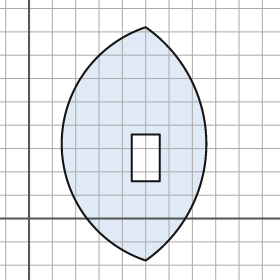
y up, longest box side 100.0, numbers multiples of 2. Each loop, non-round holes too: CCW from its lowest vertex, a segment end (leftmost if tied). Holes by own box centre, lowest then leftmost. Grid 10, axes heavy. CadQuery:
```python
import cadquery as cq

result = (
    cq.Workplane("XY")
    .moveTo(50.0, -18.0)
    .threePointArc((76.0, 32.0), (50.0, 82.0))
    .threePointArc((14.0, 32.0), (50.0, -18.0))
    .close()
    .moveTo(44.0, 16.0)
    .lineTo(56.0, 16.0)
    .lineTo(56.0, 36.0)
    .lineTo(44.0, 36.0)
    .close()
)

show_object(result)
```